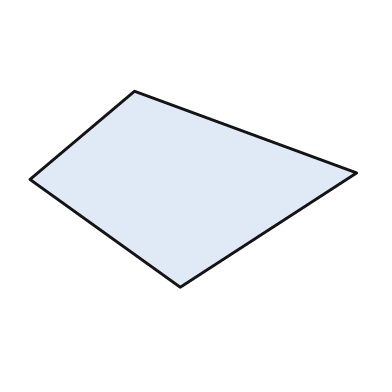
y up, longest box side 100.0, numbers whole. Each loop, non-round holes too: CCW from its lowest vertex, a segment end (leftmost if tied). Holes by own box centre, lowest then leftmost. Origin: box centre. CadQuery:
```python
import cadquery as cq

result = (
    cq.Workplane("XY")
    .moveTo(-4.0, -30.0)
    .lineTo(50.0, 5.0)
    .lineTo(-18.0, 30.0)
    .lineTo(-50.0, 3.0)
    .close()
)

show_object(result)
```